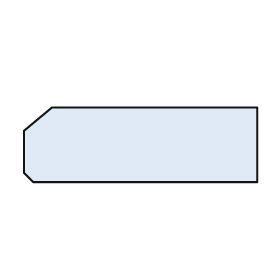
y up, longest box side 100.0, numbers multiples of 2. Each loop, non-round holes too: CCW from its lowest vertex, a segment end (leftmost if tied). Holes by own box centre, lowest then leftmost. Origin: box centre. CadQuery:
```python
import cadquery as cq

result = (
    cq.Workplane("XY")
    .moveTo(-46.0, -16.0)
    .lineTo(50.0, -16.0)
    .lineTo(50.0, 16.0)
    .lineTo(-38.0, 16.0)
    .lineTo(-50.0, 6.0)
    .lineTo(-50.0, -12.0)
    .close()
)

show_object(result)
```